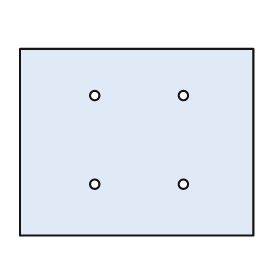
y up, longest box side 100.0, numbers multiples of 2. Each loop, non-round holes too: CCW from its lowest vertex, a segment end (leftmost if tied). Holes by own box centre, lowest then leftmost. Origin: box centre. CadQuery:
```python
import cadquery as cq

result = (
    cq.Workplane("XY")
    .moveTo(-50.0, -40.0)
    .lineTo(50.0, -40.0)
    .lineTo(50.0, 40.0)
    .lineTo(-50.0, 40.0)
    .close()
    .moveTo(-18.0, -18.0)
    .circle(2.0)
    .moveTo(20.0, -18.0)
    .circle(2.0)
    .moveTo(-18.0, 20.0)
    .circle(2.0)
    .moveTo(20.0, 20.0)
    .circle(2.0)
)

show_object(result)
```